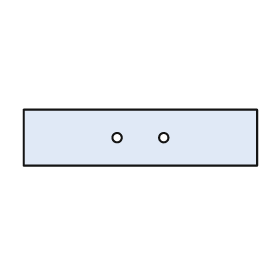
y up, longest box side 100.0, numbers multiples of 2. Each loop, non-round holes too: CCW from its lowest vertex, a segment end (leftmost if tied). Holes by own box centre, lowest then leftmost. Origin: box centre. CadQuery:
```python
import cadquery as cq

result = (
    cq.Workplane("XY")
    .moveTo(-50.0, -12.0)
    .lineTo(50.0, -12.0)
    .lineTo(50.0, 12.0)
    .lineTo(-50.0, 12.0)
    .close()
    .moveTo(-10.0, 0.0)
    .circle(2.0)
    .moveTo(10.0, 0.0)
    .circle(2.0)
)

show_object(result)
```